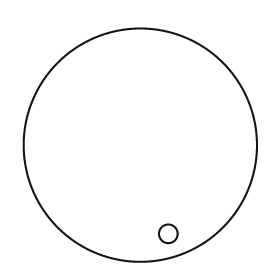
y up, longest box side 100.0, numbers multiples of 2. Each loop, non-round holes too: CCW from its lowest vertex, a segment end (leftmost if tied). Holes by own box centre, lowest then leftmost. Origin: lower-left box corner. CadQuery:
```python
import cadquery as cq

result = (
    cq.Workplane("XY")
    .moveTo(50.0, 50.0)
    .circle(50.0)
    .moveTo(62.0, 12.0)
    .circle(4.0)
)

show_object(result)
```